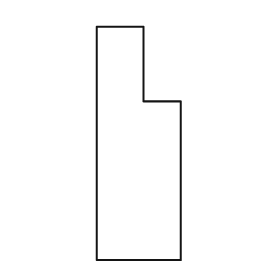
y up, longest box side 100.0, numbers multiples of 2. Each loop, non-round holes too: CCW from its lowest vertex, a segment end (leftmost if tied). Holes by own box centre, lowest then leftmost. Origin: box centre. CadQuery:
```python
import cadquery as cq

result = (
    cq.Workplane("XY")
    .moveTo(-18.0, -50.0)
    .lineTo(18.0, -50.0)
    .lineTo(18.0, 18.0)
    .lineTo(2.0, 18.0)
    .lineTo(2.0, 50.0)
    .lineTo(-18.0, 50.0)
    .close()
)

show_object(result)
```